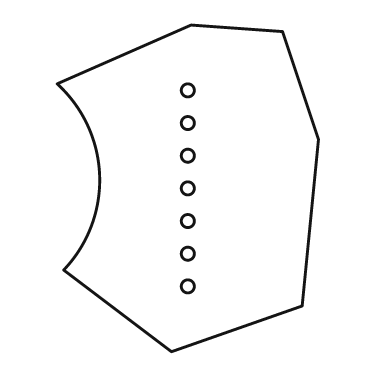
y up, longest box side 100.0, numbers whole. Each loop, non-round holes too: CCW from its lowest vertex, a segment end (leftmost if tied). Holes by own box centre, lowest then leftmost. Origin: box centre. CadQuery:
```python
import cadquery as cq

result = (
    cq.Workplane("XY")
    .moveTo(-5.0, -50.0)
    .lineTo(35.0, -36.0)
    .lineTo(40.0, 15.0)
    .lineTo(29.0, 48.0)
    .lineTo(1.0, 50.0)
    .lineTo(-40.0, 32.0)
    .threePointArc((-27.0, 4.0), (-38.0, -25.0))
    .close()
    .moveTo(0.0, -30.0)
    .circle(2.0)
    .moveTo(0.0, -20.0)
    .circle(2.0)
    .moveTo(0.0, -10.0)
    .circle(2.0)
    .moveTo(0.0, 0.0)
    .circle(2.0)
    .moveTo(0.0, 10.0)
    .circle(2.0)
    .moveTo(0.0, 20.0)
    .circle(2.0)
    .moveTo(0.0, 30.0)
    .circle(2.0)
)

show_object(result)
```